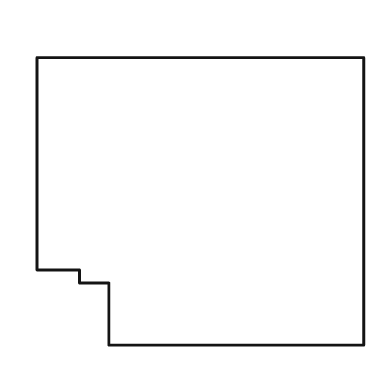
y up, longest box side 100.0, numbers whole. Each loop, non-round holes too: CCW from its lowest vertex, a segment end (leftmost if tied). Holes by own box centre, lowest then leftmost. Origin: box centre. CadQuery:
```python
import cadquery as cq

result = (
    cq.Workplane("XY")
    .moveTo(-28.0, -44.0)
    .lineTo(50.0, -44.0)
    .lineTo(50.0, 44.0)
    .lineTo(-50.0, 44.0)
    .lineTo(-50.0, -21.0)
    .lineTo(-37.0, -21.0)
    .lineTo(-37.0, -25.0)
    .lineTo(-28.0, -25.0)
    .close()
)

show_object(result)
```